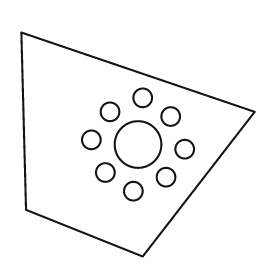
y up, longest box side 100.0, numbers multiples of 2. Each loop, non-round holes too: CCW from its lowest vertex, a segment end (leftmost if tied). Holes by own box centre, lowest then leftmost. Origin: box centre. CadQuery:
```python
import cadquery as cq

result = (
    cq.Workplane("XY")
    .moveTo(2.0, -48.0)
    .lineTo(50.0, 14.0)
    .lineTo(-50.0, 48.0)
    .lineTo(-48.0, -28.0)
    .close()
    .moveTo(-2.0, -20.0)
    .circle(4.0)
    .moveTo(12.0, -14.0)
    .circle(4.0)
    .moveTo(-14.0, -12.0)
    .circle(4.0)
    .moveTo(20.0, -2.0)
    .circle(4.0)
    .moveTo(0.0, 0.0)
    .circle(10.0)
    .moveTo(-20.0, 2.0)
    .circle(4.0)
    .moveTo(14.0, 12.0)
    .circle(4.0)
    .moveTo(-12.0, 14.0)
    .circle(4.0)
    .moveTo(2.0, 20.0)
    .circle(4.0)
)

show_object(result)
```